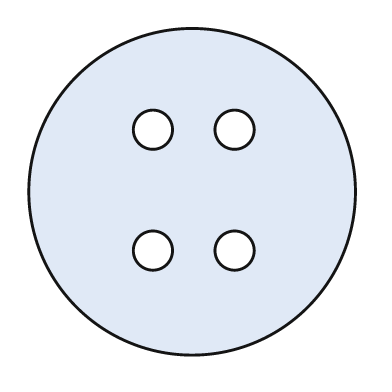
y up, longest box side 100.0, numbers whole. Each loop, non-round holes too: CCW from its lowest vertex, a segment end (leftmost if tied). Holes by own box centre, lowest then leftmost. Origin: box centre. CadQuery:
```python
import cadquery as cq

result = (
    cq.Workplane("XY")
    .moveTo(0.0, 0.0)
    .circle(50.0)
    .moveTo(-12.0, -18.0)
    .circle(6.0)
    .moveTo(13.0, -18.0)
    .circle(6.0)
    .moveTo(-12.0, 19.0)
    .circle(6.0)
    .moveTo(13.0, 19.0)
    .circle(6.0)
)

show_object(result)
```